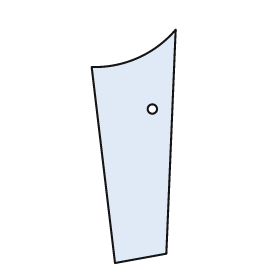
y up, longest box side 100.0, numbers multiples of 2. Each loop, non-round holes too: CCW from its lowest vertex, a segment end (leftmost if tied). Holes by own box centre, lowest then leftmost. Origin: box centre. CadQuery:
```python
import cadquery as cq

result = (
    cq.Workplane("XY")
    .moveTo(-8.0, -50.0)
    .lineTo(14.0, -46.0)
    .lineTo(18.0, 50.0)
    .threePointArc((2.0, 38.0), (-18.0, 34.0))
    .close()
    .moveTo(8.0, 16.0)
    .circle(2.0)
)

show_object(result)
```